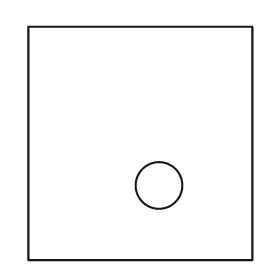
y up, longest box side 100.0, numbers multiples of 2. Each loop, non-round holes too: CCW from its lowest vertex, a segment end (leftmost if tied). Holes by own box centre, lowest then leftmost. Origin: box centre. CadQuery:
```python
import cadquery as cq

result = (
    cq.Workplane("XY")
    .moveTo(-48.0, -50.0)
    .lineTo(48.0, -50.0)
    .lineTo(48.0, 50.0)
    .lineTo(-48.0, 50.0)
    .close()
    .moveTo(8.0, -18.0)
    .circle(10.0)
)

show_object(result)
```